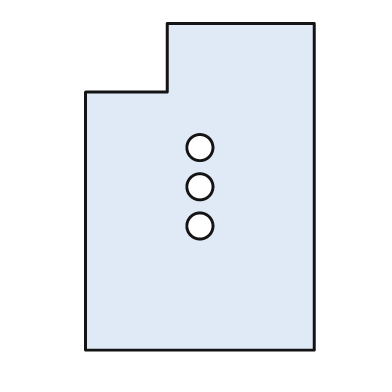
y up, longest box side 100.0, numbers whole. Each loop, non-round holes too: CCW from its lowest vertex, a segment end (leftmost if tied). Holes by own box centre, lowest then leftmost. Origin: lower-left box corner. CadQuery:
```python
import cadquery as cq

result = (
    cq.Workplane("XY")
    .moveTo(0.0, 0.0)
    .lineTo(70.0, 0.0)
    .lineTo(70.0, 100.0)
    .lineTo(25.0, 100.0)
    .lineTo(25.0, 79.0)
    .lineTo(0.0, 79.0)
    .close()
    .moveTo(35.0, 38.0)
    .circle(4.0)
    .moveTo(35.0, 50.0)
    .circle(4.0)
    .moveTo(35.0, 62.0)
    .circle(4.0)
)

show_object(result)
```